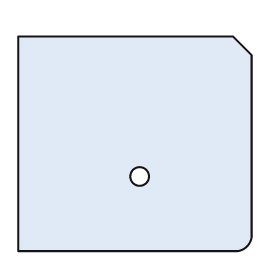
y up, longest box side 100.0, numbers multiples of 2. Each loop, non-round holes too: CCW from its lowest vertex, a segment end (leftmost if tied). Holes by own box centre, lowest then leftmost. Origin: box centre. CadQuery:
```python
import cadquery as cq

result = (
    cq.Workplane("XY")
    .moveTo(-50.0, -46.0)
    .lineTo(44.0, -46.0)
    .threePointArc((48.0, -44.0), (50.0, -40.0))
    .lineTo(50.0, 38.0)
    .lineTo(42.0, 46.0)
    .lineTo(-50.0, 46.0)
    .close()
    .moveTo(2.0, -14.0)
    .circle(4.0)
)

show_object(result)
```